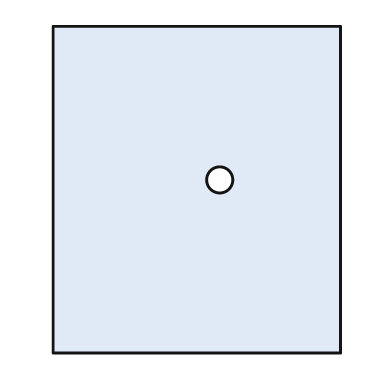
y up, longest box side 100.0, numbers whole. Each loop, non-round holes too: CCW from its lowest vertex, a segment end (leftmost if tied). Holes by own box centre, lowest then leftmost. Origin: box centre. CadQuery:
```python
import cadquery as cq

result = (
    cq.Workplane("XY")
    .moveTo(-44.0, -50.0)
    .lineTo(44.0, -50.0)
    .lineTo(44.0, 50.0)
    .lineTo(-44.0, 50.0)
    .close()
    .moveTo(7.0, 3.0)
    .circle(4.0)
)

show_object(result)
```